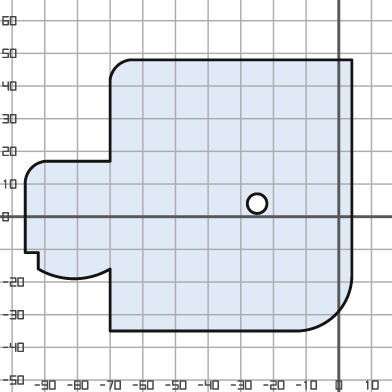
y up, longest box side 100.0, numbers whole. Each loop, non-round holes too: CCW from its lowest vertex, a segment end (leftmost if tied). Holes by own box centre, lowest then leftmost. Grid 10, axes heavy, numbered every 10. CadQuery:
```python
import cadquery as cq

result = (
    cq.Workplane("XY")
    .moveTo(-70.0, -35.0)
    .lineTo(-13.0, -35.0)
    .threePointArc((-1.0, -30.0), (4.0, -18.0))
    .lineTo(4.0, 48.0)
    .lineTo(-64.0, 48.0)
    .threePointArc((-68.0, 46.0), (-70.0, 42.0))
    .lineTo(-70.0, 17.0)
    .lineTo(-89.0, 17.0)
    .threePointArc((-94.0, 15.0), (-96.0, 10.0))
    .lineTo(-96.0, -11.0)
    .lineTo(-92.0, -11.0)
    .lineTo(-92.0, -16.0)
    .threePointArc((-81.0, -19.0), (-70.0, -16.0))
    .close()
    .moveTo(-25.0, 4.0)
    .circle(3.0)
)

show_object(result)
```